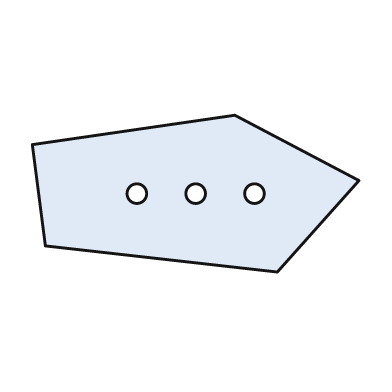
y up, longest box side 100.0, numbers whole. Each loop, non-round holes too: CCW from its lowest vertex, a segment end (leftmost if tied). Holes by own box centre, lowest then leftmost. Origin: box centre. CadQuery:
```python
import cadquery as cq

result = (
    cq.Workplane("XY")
    .moveTo(25.0, -24.0)
    .lineTo(50.0, 4.0)
    .lineTo(12.0, 24.0)
    .lineTo(-50.0, 15.0)
    .lineTo(-46.0, -16.0)
    .close()
    .moveTo(-18.0, 0.0)
    .circle(3.0)
    .moveTo(0.0, 0.0)
    .circle(3.0)
    .moveTo(18.0, 0.0)
    .circle(3.0)
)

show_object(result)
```